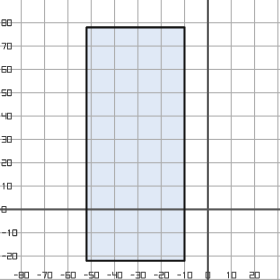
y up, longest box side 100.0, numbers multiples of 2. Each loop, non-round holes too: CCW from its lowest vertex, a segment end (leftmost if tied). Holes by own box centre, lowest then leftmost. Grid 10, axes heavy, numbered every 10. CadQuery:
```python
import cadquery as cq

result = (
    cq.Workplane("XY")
    .moveTo(-52.0, -22.0)
    .lineTo(-10.0, -22.0)
    .lineTo(-10.0, 78.0)
    .lineTo(-52.0, 78.0)
    .close()
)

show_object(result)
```